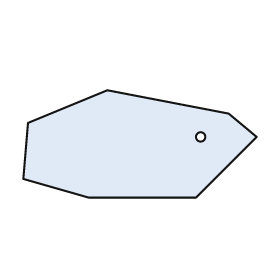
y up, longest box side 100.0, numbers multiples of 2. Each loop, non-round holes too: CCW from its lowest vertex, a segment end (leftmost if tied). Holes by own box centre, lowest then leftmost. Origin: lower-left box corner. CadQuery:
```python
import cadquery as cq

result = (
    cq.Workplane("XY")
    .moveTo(28.0, 0.0)
    .lineTo(74.0, 0.0)
    .lineTo(100.0, 26.0)
    .lineTo(88.0, 36.0)
    .lineTo(36.0, 46.0)
    .lineTo(2.0, 32.0)
    .lineTo(0.0, 8.0)
    .close()
    .moveTo(76.0, 26.0)
    .circle(2.0)
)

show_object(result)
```